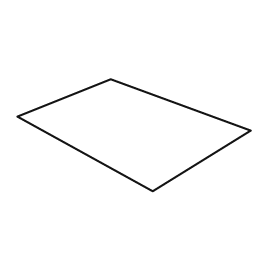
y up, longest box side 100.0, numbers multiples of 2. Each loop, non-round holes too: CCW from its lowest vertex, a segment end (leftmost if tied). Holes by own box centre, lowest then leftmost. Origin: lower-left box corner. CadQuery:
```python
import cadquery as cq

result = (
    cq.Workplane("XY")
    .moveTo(58.0, 0.0)
    .lineTo(100.0, 26.0)
    .lineTo(40.0, 48.0)
    .lineTo(0.0, 32.0)
    .close()
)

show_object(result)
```